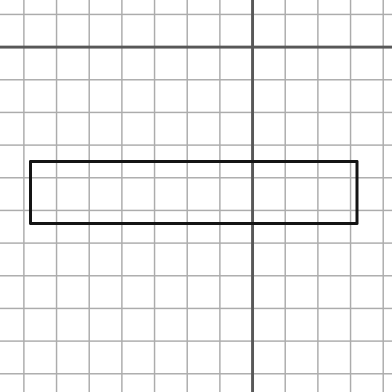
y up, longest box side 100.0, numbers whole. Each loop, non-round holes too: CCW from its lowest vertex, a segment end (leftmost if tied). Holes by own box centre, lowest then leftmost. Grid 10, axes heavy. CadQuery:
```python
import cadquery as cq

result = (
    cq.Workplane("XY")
    .moveTo(-68.0, -54.0)
    .lineTo(32.0, -54.0)
    .lineTo(32.0, -35.0)
    .lineTo(-68.0, -35.0)
    .close()
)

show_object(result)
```